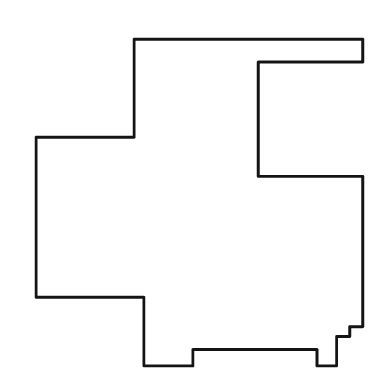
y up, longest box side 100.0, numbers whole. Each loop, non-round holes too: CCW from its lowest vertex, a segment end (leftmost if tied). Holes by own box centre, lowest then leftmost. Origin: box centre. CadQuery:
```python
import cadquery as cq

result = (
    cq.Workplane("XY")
    .moveTo(-17.0, -50.0)
    .lineTo(-2.0, -50.0)
    .lineTo(-2.0, -45.0)
    .lineTo(36.0, -45.0)
    .lineTo(36.0, -50.0)
    .lineTo(42.0, -50.0)
    .lineTo(42.0, -41.0)
    .lineTo(46.0, -41.0)
    .lineTo(46.0, -38.0)
    .lineTo(50.0, -38.0)
    .lineTo(50.0, 8.0)
    .lineTo(18.0, 8.0)
    .lineTo(18.0, 43.0)
    .lineTo(50.0, 43.0)
    .lineTo(50.0, 50.0)
    .lineTo(-20.0, 50.0)
    .lineTo(-20.0, 20.0)
    .lineTo(-50.0, 20.0)
    .lineTo(-50.0, -29.0)
    .lineTo(-17.0, -29.0)
    .close()
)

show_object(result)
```